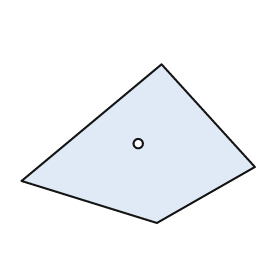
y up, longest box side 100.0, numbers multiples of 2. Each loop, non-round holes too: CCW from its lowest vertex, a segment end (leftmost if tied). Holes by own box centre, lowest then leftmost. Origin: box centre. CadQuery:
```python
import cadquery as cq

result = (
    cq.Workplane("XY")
    .moveTo(8.0, -34.0)
    .lineTo(50.0, -10.0)
    .lineTo(10.0, 34.0)
    .lineTo(-50.0, -16.0)
    .close()
    .moveTo(0.0, 0.0)
    .circle(2.0)
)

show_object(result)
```